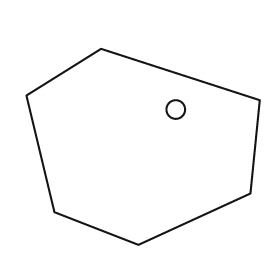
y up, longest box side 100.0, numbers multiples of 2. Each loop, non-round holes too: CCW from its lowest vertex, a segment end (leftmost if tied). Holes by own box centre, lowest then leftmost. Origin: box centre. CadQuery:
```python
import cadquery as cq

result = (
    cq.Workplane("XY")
    .moveTo(-2.0, -42.0)
    .lineTo(46.0, -20.0)
    .lineTo(50.0, 20.0)
    .lineTo(-18.0, 42.0)
    .lineTo(-50.0, 22.0)
    .lineTo(-38.0, -28.0)
    .close()
    .moveTo(14.0, 16.0)
    .circle(4.0)
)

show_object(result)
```